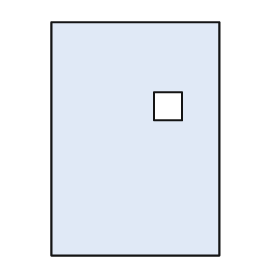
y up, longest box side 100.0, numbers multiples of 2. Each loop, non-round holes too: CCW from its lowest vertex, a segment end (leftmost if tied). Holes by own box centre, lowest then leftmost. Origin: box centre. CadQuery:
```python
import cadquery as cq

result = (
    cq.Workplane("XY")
    .moveTo(-36.0, -50.0)
    .lineTo(36.0, -50.0)
    .lineTo(36.0, 50.0)
    .lineTo(-36.0, 50.0)
    .close()
    .moveTo(8.0, 8.0)
    .lineTo(20.0, 8.0)
    .lineTo(20.0, 20.0)
    .lineTo(8.0, 20.0)
    .close()
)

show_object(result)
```